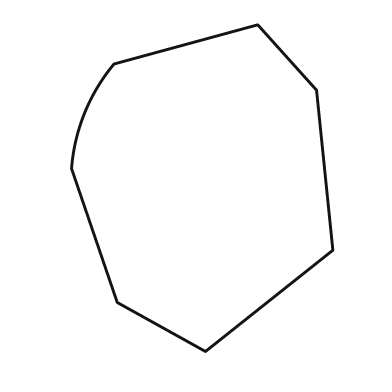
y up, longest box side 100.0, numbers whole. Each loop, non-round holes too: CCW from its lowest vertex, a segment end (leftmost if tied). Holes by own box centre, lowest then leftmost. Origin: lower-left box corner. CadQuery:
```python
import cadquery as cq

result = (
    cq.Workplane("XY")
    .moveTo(41.0, 0.0)
    .lineTo(80.0, 31.0)
    .lineTo(75.0, 80.0)
    .lineTo(57.0, 100.0)
    .lineTo(13.0, 88.0)
    .threePointArc((4.0, 73.0), (0.0, 56.0))
    .lineTo(14.0, 15.0)
    .close()
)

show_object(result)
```